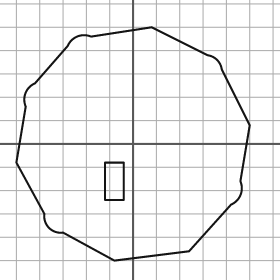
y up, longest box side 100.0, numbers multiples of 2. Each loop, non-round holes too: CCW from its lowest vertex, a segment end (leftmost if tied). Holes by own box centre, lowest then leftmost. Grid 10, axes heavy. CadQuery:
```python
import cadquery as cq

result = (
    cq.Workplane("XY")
    .moveTo(-8.0, -50.0)
    .lineTo(24.0, -46.0)
    .lineTo(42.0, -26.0)
    .threePointArc((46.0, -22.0), (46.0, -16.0))
    .lineTo(50.0, 8.0)
    .lineTo(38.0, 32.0)
    .threePointArc((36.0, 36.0), (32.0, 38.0))
    .lineTo(8.0, 50.0)
    .lineTo(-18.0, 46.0)
    .threePointArc((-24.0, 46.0), (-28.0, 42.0))
    .lineTo(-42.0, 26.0)
    .threePointArc((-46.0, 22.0), (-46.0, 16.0))
    .lineTo(-50.0, -8.0)
    .lineTo(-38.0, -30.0)
    .threePointArc((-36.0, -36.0), (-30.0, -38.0))
    .close()
    .moveTo(-12.0, -24.0)
    .lineTo(-4.0, -24.0)
    .lineTo(-4.0, -8.0)
    .lineTo(-12.0, -8.0)
    .close()
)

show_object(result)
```